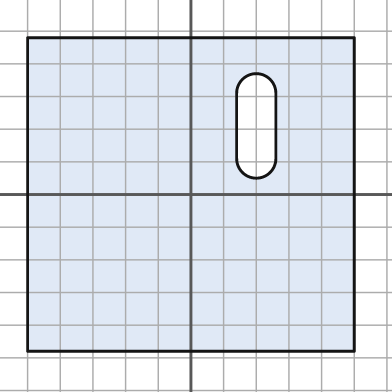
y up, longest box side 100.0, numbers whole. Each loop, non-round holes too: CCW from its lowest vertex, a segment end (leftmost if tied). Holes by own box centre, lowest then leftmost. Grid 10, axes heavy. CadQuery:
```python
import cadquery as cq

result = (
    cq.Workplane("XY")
    .moveTo(-50.0, -48.0)
    .lineTo(50.0, -48.0)
    .lineTo(50.0, 48.0)
    .lineTo(-50.0, 48.0)
    .close()
    .moveTo(14.0, 11.0)
    .threePointArc((20.0, 5.0), (26.0, 11.0))
    .lineTo(26.0, 31.0)
    .threePointArc((20.0, 37.0), (14.0, 31.0))
    .close()
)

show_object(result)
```